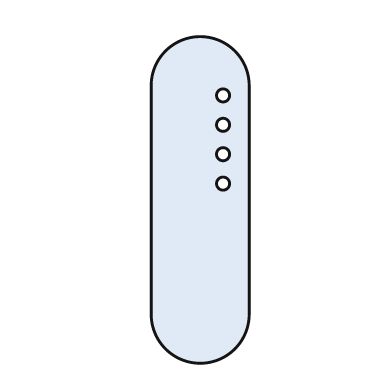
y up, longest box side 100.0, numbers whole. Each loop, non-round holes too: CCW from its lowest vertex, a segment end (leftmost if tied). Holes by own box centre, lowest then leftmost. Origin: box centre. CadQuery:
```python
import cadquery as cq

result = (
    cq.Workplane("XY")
    .moveTo(-15.0, -35.0)
    .threePointArc((0.0, -50.0), (15.0, -35.0))
    .lineTo(15.0, 35.0)
    .threePointArc((0.0, 50.0), (-15.0, 35.0))
    .close()
    .moveTo(7.0, 5.0)
    .circle(2.0)
    .moveTo(7.0, 14.0)
    .circle(2.0)
    .moveTo(7.0, 23.0)
    .circle(2.0)
    .moveTo(7.0, 32.0)
    .circle(2.0)
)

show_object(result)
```